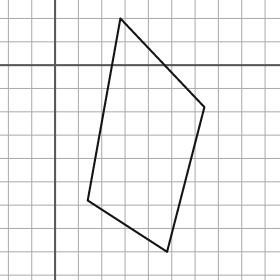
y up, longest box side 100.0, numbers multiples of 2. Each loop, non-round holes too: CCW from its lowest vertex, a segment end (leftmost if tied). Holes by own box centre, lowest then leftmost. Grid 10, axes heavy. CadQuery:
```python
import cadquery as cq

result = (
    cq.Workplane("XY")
    .moveTo(48.0, -80.0)
    .lineTo(64.0, -18.0)
    .lineTo(28.0, 20.0)
    .lineTo(14.0, -58.0)
    .close()
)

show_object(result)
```